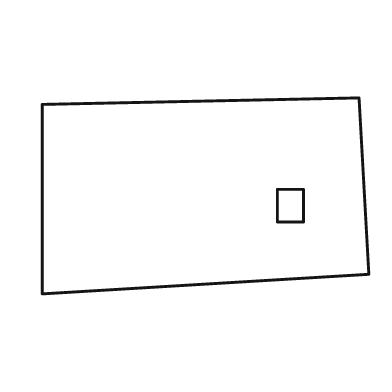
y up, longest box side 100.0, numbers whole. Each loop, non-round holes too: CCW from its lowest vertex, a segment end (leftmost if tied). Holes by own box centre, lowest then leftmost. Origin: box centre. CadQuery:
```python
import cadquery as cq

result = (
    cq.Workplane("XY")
    .moveTo(-50.0, -30.0)
    .lineTo(50.0, -24.0)
    .lineTo(47.0, 30.0)
    .lineTo(-50.0, 28.0)
    .close()
    .moveTo(22.0, -8.0)
    .lineTo(30.0, -8.0)
    .lineTo(30.0, 2.0)
    .lineTo(22.0, 2.0)
    .close()
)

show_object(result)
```